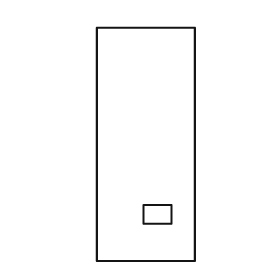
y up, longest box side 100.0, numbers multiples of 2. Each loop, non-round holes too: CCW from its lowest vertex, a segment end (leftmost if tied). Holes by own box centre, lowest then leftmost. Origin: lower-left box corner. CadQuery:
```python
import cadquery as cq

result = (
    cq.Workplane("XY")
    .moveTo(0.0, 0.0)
    .lineTo(42.0, 0.0)
    .lineTo(42.0, 100.0)
    .lineTo(0.0, 100.0)
    .close()
    .moveTo(20.0, 16.0)
    .lineTo(32.0, 16.0)
    .lineTo(32.0, 24.0)
    .lineTo(20.0, 24.0)
    .close()
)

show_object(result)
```